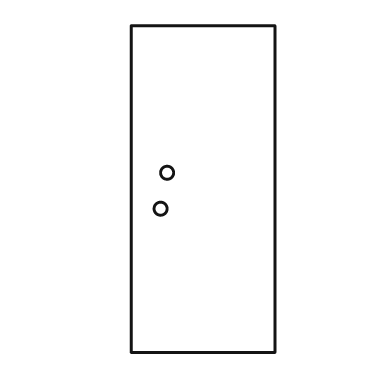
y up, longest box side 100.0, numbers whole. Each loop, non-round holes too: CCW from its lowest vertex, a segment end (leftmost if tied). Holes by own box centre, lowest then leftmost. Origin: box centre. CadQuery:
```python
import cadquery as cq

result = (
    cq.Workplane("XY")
    .moveTo(-22.0, -50.0)
    .lineTo(22.0, -50.0)
    .lineTo(22.0, 50.0)
    .lineTo(-22.0, 50.0)
    .close()
    .moveTo(-13.0, -6.0)
    .circle(2.0)
    .moveTo(-11.0, 5.0)
    .circle(2.0)
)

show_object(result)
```